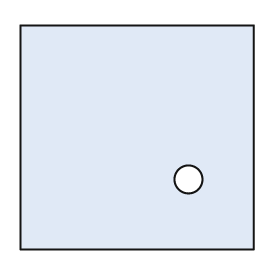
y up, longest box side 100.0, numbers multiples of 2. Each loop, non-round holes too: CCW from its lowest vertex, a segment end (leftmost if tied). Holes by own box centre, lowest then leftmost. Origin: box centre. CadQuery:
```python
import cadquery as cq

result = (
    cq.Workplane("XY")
    .moveTo(-50.0, -48.0)
    .lineTo(50.0, -48.0)
    .lineTo(50.0, 48.0)
    .lineTo(-50.0, 48.0)
    .close()
    .moveTo(22.0, -18.0)
    .circle(6.0)
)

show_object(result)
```